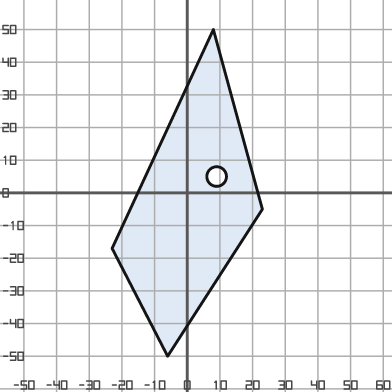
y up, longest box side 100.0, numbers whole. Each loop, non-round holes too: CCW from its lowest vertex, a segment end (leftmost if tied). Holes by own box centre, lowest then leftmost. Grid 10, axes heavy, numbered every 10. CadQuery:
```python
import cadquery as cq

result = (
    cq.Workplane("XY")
    .moveTo(-6.0, -50.0)
    .lineTo(23.0, -5.0)
    .lineTo(8.0, 50.0)
    .lineTo(-23.0, -17.0)
    .close()
    .moveTo(9.0, 5.0)
    .circle(3.0)
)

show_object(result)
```